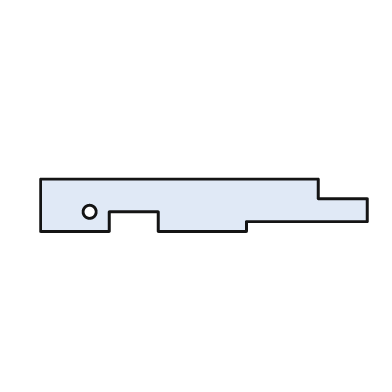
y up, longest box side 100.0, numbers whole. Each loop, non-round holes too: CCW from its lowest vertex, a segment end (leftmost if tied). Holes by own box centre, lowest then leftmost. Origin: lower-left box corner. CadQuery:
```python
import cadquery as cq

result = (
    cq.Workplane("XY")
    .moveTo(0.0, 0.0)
    .lineTo(21.0, 0.0)
    .lineTo(21.0, 6.0)
    .lineTo(36.0, 6.0)
    .lineTo(36.0, 0.0)
    .lineTo(63.0, 0.0)
    .lineTo(63.0, 3.0)
    .lineTo(100.0, 3.0)
    .lineTo(100.0, 10.0)
    .lineTo(85.0, 10.0)
    .lineTo(85.0, 16.0)
    .lineTo(0.0, 16.0)
    .close()
    .moveTo(15.0, 6.0)
    .circle(2.0)
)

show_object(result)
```